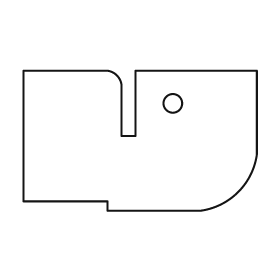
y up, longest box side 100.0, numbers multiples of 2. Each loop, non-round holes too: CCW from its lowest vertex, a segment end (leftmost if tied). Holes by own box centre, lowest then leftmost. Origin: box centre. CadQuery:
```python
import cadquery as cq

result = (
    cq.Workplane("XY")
    .moveTo(-14.0, -30.0)
    .lineTo(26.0, -30.0)
    .threePointArc((42.0, -22.0), (50.0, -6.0))
    .lineTo(50.0, 30.0)
    .lineTo(-2.0, 30.0)
    .lineTo(-2.0, 2.0)
    .lineTo(-8.0, 2.0)
    .lineTo(-8.0, 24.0)
    .threePointArc((-10.0, 28.0), (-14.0, 30.0))
    .lineTo(-50.0, 30.0)
    .lineTo(-50.0, -26.0)
    .lineTo(-14.0, -26.0)
    .close()
    .moveTo(14.0, 16.0)
    .circle(4.0)
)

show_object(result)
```